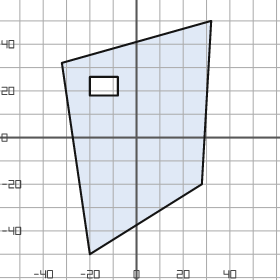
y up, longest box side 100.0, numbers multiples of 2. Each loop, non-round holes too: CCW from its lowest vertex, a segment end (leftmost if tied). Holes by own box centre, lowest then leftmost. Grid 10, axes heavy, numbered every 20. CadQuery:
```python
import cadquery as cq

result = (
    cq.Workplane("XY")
    .moveTo(-20.0, -50.0)
    .lineTo(28.0, -20.0)
    .lineTo(32.0, 50.0)
    .lineTo(-32.0, 32.0)
    .close()
    .moveTo(-20.0, 18.0)
    .lineTo(-8.0, 18.0)
    .lineTo(-8.0, 26.0)
    .lineTo(-20.0, 26.0)
    .close()
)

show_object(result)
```